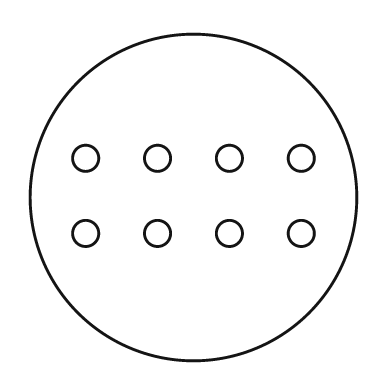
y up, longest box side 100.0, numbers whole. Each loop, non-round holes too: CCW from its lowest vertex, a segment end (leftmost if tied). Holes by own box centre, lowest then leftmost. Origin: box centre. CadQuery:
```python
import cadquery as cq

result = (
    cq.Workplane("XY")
    .moveTo(0.0, 0.0)
    .circle(50.0)
    .moveTo(-33.0, -11.0)
    .circle(4.0)
    .moveTo(-11.0, -11.0)
    .circle(4.0)
    .moveTo(11.0, -11.0)
    .circle(4.0)
    .moveTo(33.0, -11.0)
    .circle(4.0)
    .moveTo(-33.0, 12.0)
    .circle(4.0)
    .moveTo(-11.0, 12.0)
    .circle(4.0)
    .moveTo(11.0, 12.0)
    .circle(4.0)
    .moveTo(33.0, 12.0)
    .circle(4.0)
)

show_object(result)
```